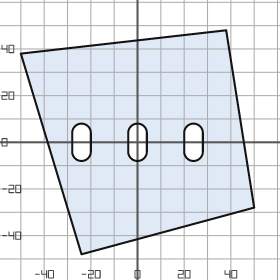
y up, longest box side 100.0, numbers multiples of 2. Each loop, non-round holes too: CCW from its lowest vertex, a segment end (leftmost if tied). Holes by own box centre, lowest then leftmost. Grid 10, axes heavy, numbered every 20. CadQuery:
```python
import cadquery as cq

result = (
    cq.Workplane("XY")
    .moveTo(-24.0, -48.0)
    .lineTo(50.0, -28.0)
    .lineTo(38.0, 48.0)
    .lineTo(-50.0, 38.0)
    .close()
    .moveTo(-28.0, -4.0)
    .threePointArc((-24.0, -8.0), (-20.0, -4.0))
    .lineTo(-20.0, 4.0)
    .threePointArc((-24.0, 8.0), (-28.0, 4.0))
    .close()
    .moveTo(-4.0, -4.0)
    .threePointArc((0.0, -8.0), (4.0, -4.0))
    .lineTo(4.0, 4.0)
    .threePointArc((0.0, 8.0), (-4.0, 4.0))
    .close()
    .moveTo(20.0, -4.0)
    .threePointArc((24.0, -8.0), (28.0, -4.0))
    .lineTo(28.0, 4.0)
    .threePointArc((24.0, 8.0), (20.0, 4.0))
    .close()
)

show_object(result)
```